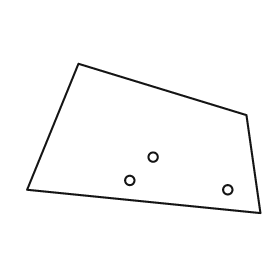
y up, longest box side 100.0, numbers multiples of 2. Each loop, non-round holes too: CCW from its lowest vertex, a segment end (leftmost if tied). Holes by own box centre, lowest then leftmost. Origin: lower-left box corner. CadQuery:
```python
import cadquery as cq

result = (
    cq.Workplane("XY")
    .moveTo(100.0, 0.0)
    .lineTo(94.0, 42.0)
    .lineTo(22.0, 64.0)
    .lineTo(0.0, 10.0)
    .close()
    .moveTo(86.0, 10.0)
    .circle(2.0)
    .moveTo(44.0, 14.0)
    .circle(2.0)
    .moveTo(54.0, 24.0)
    .circle(2.0)
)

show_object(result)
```